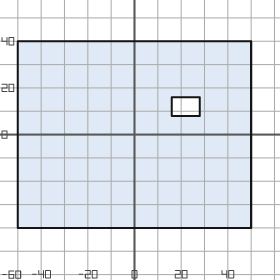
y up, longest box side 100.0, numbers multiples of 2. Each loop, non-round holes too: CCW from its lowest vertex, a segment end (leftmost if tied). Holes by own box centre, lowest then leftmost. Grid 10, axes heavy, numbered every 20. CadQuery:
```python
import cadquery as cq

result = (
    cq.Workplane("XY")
    .moveTo(-50.0, -40.0)
    .lineTo(50.0, -40.0)
    .lineTo(50.0, 40.0)
    .lineTo(-50.0, 40.0)
    .close()
    .moveTo(16.0, 8.0)
    .lineTo(28.0, 8.0)
    .lineTo(28.0, 16.0)
    .lineTo(16.0, 16.0)
    .close()
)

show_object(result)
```